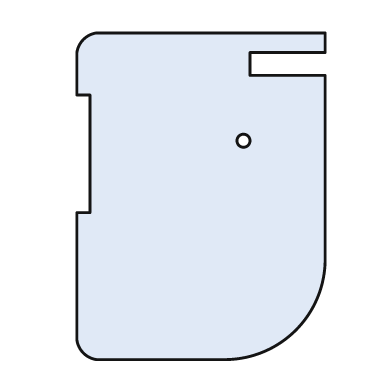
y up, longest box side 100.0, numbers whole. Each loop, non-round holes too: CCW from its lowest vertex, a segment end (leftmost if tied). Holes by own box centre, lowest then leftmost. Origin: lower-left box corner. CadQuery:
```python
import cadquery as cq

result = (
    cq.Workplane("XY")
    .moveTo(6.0, 0.0)
    .lineTo(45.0, 0.0)
    .threePointArc((67.0, 9.0), (76.0, 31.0))
    .lineTo(76.0, 87.0)
    .lineTo(53.0, 87.0)
    .lineTo(53.0, 94.0)
    .lineTo(76.0, 94.0)
    .lineTo(76.0, 100.0)
    .lineTo(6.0, 100.0)
    .threePointArc((2.0, 98.0), (0.0, 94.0))
    .lineTo(0.0, 81.0)
    .lineTo(4.0, 81.0)
    .lineTo(4.0, 45.0)
    .lineTo(0.0, 45.0)
    .lineTo(0.0, 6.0)
    .threePointArc((2.0, 2.0), (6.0, 0.0))
    .close()
    .moveTo(51.0, 67.0)
    .circle(2.0)
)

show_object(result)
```